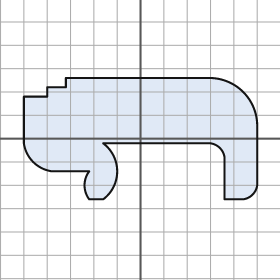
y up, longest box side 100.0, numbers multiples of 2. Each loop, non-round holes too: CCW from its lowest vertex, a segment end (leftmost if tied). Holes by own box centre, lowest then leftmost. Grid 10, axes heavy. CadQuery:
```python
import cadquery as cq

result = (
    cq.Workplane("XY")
    .moveTo(-22.0, -26.0)
    .lineTo(-16.0, -26.0)
    .threePointArc((-10.0, -14.0), (-16.0, -2.0))
    .lineTo(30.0, -2.0)
    .threePointArc((34.0, -4.0), (36.0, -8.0))
    .lineTo(36.0, -26.0)
    .lineTo(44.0, -26.0)
    .threePointArc((48.0, -24.0), (50.0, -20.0))
    .lineTo(50.0, 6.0)
    .threePointArc((44.0, 20.0), (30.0, 26.0))
    .lineTo(-32.0, 26.0)
    .lineTo(-32.0, 22.0)
    .lineTo(-40.0, 22.0)
    .lineTo(-40.0, 18.0)
    .lineTo(-50.0, 18.0)
    .lineTo(-50.0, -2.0)
    .threePointArc((-46.0, -10.0), (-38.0, -14.0))
    .lineTo(-22.0, -14.0)
    .threePointArc((-24.0, -20.0), (-22.0, -26.0))
    .close()
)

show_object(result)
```